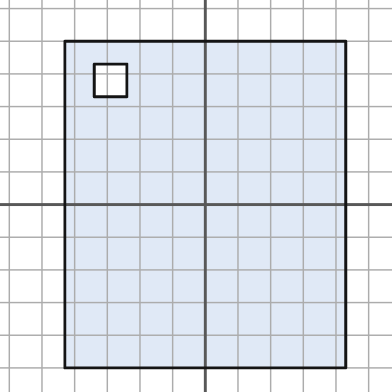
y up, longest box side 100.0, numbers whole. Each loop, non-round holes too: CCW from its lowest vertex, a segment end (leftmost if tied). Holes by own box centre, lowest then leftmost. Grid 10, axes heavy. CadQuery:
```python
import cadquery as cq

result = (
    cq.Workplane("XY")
    .moveTo(-43.0, -50.0)
    .lineTo(43.0, -50.0)
    .lineTo(43.0, 50.0)
    .lineTo(-43.0, 50.0)
    .close()
    .moveTo(-34.0, 33.0)
    .lineTo(-24.0, 33.0)
    .lineTo(-24.0, 43.0)
    .lineTo(-34.0, 43.0)
    .close()
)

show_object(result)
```